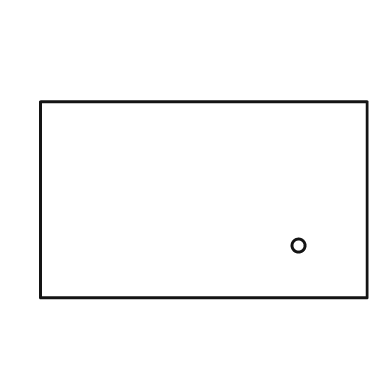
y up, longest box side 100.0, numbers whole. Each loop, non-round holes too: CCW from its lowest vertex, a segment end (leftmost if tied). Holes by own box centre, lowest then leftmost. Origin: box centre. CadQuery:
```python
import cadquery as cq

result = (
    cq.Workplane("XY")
    .moveTo(-50.0, -30.0)
    .lineTo(50.0, -30.0)
    .lineTo(50.0, 30.0)
    .lineTo(-50.0, 30.0)
    .close()
    .moveTo(29.0, -14.0)
    .circle(2.0)
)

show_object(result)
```